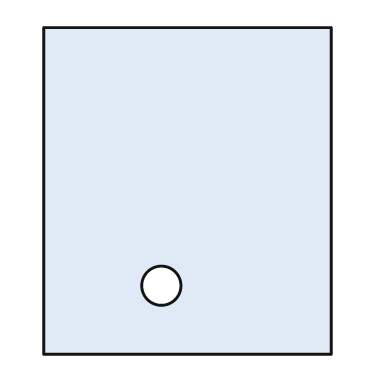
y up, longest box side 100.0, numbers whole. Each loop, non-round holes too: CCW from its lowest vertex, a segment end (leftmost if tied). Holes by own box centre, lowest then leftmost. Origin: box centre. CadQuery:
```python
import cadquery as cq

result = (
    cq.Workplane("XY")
    .moveTo(-44.0, -50.0)
    .lineTo(44.0, -50.0)
    .lineTo(44.0, 50.0)
    .lineTo(-44.0, 50.0)
    .close()
    .moveTo(-8.0, -29.0)
    .circle(6.0)
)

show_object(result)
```